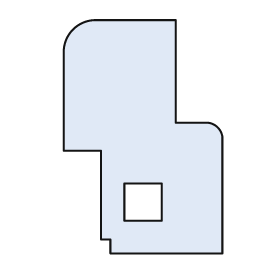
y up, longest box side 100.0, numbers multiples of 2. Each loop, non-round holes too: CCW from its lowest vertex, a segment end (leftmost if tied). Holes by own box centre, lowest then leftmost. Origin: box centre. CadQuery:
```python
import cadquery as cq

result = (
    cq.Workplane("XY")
    .moveTo(-14.0, -50.0)
    .lineTo(34.0, -50.0)
    .lineTo(34.0, 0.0)
    .threePointArc((32.0, 4.0), (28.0, 6.0))
    .lineTo(14.0, 6.0)
    .lineTo(14.0, 50.0)
    .lineTo(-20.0, 50.0)
    .threePointArc((-30.0, 46.0), (-34.0, 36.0))
    .lineTo(-34.0, -6.0)
    .lineTo(-18.0, -6.0)
    .lineTo(-18.0, -44.0)
    .lineTo(-14.0, -44.0)
    .close()
    .moveTo(-8.0, -36.0)
    .lineTo(8.0, -36.0)
    .lineTo(8.0, -20.0)
    .lineTo(-8.0, -20.0)
    .close()
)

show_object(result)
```